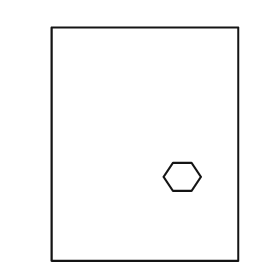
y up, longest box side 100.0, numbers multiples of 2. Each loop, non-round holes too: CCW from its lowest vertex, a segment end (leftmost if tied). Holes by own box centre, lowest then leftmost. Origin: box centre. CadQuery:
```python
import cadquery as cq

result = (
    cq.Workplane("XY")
    .moveTo(-40.0, -50.0)
    .lineTo(40.0, -50.0)
    .lineTo(40.0, 50.0)
    .lineTo(-40.0, 50.0)
    .close()
    .moveTo(12.0, -20.0)
    .lineTo(20.0, -20.0)
    .lineTo(24.0, -14.0)
    .lineTo(20.0, -8.0)
    .lineTo(12.0, -8.0)
    .lineTo(8.0, -14.0)
    .close()
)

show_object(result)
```